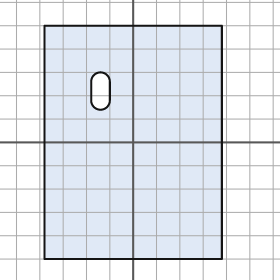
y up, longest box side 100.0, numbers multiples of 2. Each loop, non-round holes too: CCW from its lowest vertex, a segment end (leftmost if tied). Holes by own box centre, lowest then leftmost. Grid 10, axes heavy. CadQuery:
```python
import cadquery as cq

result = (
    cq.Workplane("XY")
    .moveTo(-38.0, -50.0)
    .lineTo(38.0, -50.0)
    .lineTo(38.0, 50.0)
    .lineTo(-38.0, 50.0)
    .close()
    .moveTo(-18.0, 18.0)
    .threePointArc((-14.0, 14.0), (-10.0, 18.0))
    .lineTo(-10.0, 26.0)
    .threePointArc((-14.0, 30.0), (-18.0, 26.0))
    .close()
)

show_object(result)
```